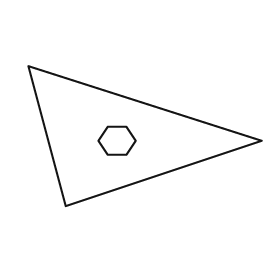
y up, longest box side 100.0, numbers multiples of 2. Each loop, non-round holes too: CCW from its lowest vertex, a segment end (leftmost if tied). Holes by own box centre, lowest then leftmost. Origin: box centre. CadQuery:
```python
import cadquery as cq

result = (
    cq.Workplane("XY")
    .moveTo(-34.0, -30.0)
    .lineTo(50.0, -2.0)
    .lineTo(-50.0, 30.0)
    .close()
    .moveTo(-16.0, -8.0)
    .lineTo(-8.0, -8.0)
    .lineTo(-4.0, -2.0)
    .lineTo(-8.0, 4.0)
    .lineTo(-16.0, 4.0)
    .lineTo(-20.0, -2.0)
    .close()
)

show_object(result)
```